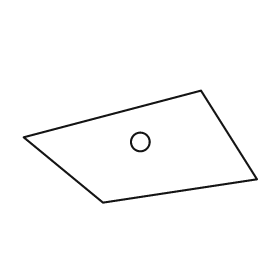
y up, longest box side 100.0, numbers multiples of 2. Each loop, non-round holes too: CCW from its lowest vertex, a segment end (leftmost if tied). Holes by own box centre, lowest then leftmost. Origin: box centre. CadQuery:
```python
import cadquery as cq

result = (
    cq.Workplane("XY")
    .moveTo(-16.0, -24.0)
    .lineTo(50.0, -14.0)
    .lineTo(26.0, 24.0)
    .lineTo(-50.0, 4.0)
    .close()
    .moveTo(0.0, 2.0)
    .circle(4.0)
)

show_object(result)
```